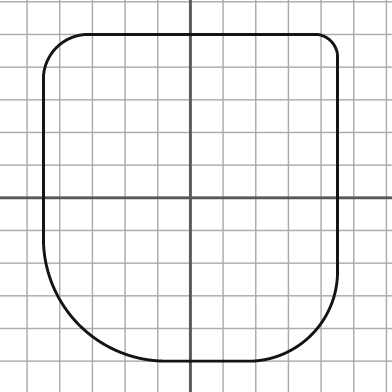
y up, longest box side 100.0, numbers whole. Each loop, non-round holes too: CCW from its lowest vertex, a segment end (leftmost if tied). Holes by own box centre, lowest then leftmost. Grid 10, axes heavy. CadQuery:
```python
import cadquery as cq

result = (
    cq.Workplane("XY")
    .moveTo(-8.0, -50.0)
    .lineTo(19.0, -50.0)
    .threePointArc((37.0, -42.0), (45.0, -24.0))
    .lineTo(45.0, 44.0)
    .threePointArc((43.0, 48.0), (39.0, 50.0))
    .lineTo(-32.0, 50.0)
    .threePointArc((-41.0, 46.0), (-45.0, 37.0))
    .lineTo(-45.0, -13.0)
    .threePointArc((-34.0, -39.0), (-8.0, -50.0))
    .close()
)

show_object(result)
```